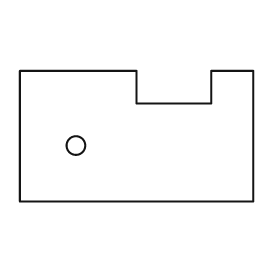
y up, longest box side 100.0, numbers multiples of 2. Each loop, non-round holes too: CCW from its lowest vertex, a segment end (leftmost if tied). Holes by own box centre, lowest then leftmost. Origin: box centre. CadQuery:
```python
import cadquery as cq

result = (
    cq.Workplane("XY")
    .moveTo(-50.0, -28.0)
    .lineTo(50.0, -28.0)
    .lineTo(50.0, 28.0)
    .lineTo(32.0, 28.0)
    .lineTo(32.0, 14.0)
    .lineTo(0.0, 14.0)
    .lineTo(0.0, 28.0)
    .lineTo(-50.0, 28.0)
    .close()
    .moveTo(-26.0, -4.0)
    .circle(4.0)
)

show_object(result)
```